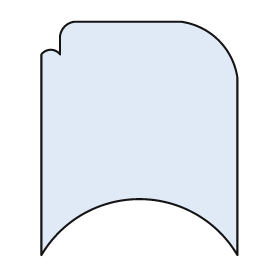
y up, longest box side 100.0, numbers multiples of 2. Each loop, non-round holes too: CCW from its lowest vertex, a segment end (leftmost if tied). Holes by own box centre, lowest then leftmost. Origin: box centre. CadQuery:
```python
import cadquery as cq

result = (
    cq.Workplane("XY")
    .moveTo(-42.0, -50.0)
    .threePointArc((0.0, -26.0), (42.0, -50.0))
    .lineTo(42.0, 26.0)
    .threePointArc((34.0, 42.0), (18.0, 50.0))
    .lineTo(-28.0, 50.0)
    .threePointArc((-32.0, 48.0), (-34.0, 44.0))
    .lineTo(-34.0, 36.0)
    .threePointArc((-38.0, 38.0), (-42.0, 36.0))
    .close()
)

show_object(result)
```